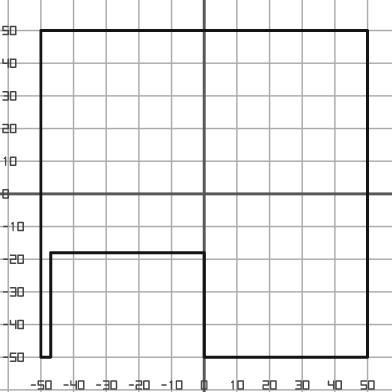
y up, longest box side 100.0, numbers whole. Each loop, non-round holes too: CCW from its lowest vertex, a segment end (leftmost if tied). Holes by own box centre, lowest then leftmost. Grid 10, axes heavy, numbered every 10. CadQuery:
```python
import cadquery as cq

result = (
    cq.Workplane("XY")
    .moveTo(-50.0, -50.0)
    .lineTo(-47.0, -50.0)
    .lineTo(-47.0, -18.0)
    .lineTo(0.0, -18.0)
    .lineTo(0.0, -50.0)
    .lineTo(50.0, -50.0)
    .lineTo(50.0, 50.0)
    .lineTo(-50.0, 50.0)
    .close()
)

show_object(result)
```